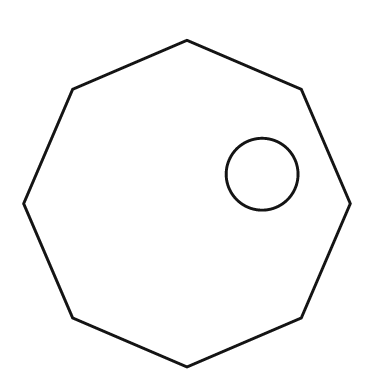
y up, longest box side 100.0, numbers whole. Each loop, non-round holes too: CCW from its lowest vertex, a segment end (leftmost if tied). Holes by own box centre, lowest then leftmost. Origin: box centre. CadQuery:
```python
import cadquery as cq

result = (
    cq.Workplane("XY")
    .moveTo(0.0, -50.0)
    .lineTo(35.0, -35.0)
    .lineTo(50.0, 0.0)
    .lineTo(35.0, 35.0)
    .lineTo(0.0, 50.0)
    .lineTo(-35.0, 35.0)
    .lineTo(-50.0, 0.0)
    .lineTo(-35.0, -35.0)
    .close()
    .moveTo(23.0, 9.0)
    .circle(11.0)
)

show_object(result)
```